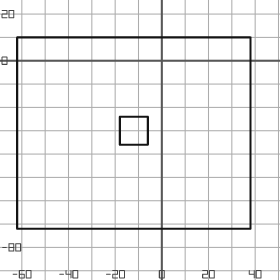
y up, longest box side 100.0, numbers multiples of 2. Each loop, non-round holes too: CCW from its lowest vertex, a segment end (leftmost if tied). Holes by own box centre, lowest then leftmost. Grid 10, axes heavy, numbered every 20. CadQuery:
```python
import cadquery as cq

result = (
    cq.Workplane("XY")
    .moveTo(-62.0, -72.0)
    .lineTo(38.0, -72.0)
    .lineTo(38.0, 10.0)
    .lineTo(-62.0, 10.0)
    .close()
    .moveTo(-18.0, -36.0)
    .lineTo(-6.0, -36.0)
    .lineTo(-6.0, -24.0)
    .lineTo(-18.0, -24.0)
    .close()
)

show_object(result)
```